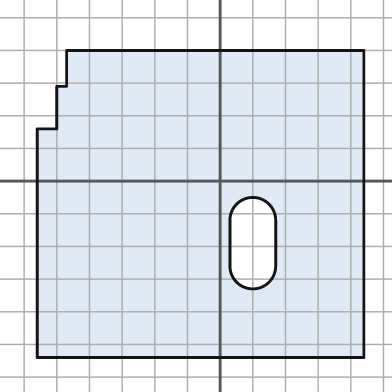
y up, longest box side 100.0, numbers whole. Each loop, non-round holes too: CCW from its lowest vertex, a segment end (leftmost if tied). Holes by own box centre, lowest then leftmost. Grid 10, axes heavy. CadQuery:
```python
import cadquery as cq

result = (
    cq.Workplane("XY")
    .moveTo(-56.0, -54.0)
    .lineTo(44.0, -54.0)
    .lineTo(44.0, 40.0)
    .lineTo(-47.0, 40.0)
    .lineTo(-47.0, 29.0)
    .lineTo(-50.0, 29.0)
    .lineTo(-50.0, 16.0)
    .lineTo(-56.0, 16.0)
    .close()
    .moveTo(3.0, -26.0)
    .threePointArc((10.0, -33.0), (17.0, -26.0))
    .lineTo(17.0, -12.0)
    .threePointArc((10.0, -5.0), (3.0, -12.0))
    .close()
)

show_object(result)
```